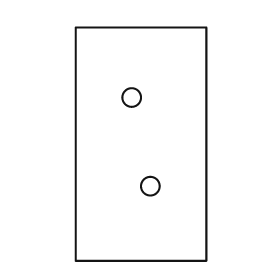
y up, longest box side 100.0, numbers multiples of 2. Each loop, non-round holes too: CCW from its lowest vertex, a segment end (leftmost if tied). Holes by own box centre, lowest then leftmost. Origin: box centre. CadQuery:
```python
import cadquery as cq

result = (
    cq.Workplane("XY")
    .moveTo(-28.0, -50.0)
    .lineTo(28.0, -50.0)
    .lineTo(28.0, 50.0)
    .lineTo(-28.0, 50.0)
    .close()
    .moveTo(4.0, -18.0)
    .circle(4.0)
    .moveTo(-4.0, 20.0)
    .circle(4.0)
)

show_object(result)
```